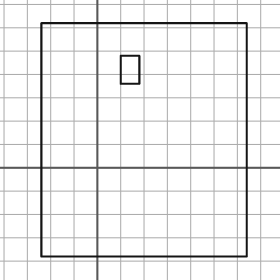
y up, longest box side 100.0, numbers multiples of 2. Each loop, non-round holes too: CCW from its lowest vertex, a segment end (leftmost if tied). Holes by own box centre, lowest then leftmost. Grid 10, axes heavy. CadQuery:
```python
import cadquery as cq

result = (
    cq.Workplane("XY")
    .moveTo(-24.0, -38.0)
    .lineTo(64.0, -38.0)
    .lineTo(64.0, 62.0)
    .lineTo(-24.0, 62.0)
    .close()
    .moveTo(10.0, 36.0)
    .lineTo(18.0, 36.0)
    .lineTo(18.0, 48.0)
    .lineTo(10.0, 48.0)
    .close()
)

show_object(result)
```